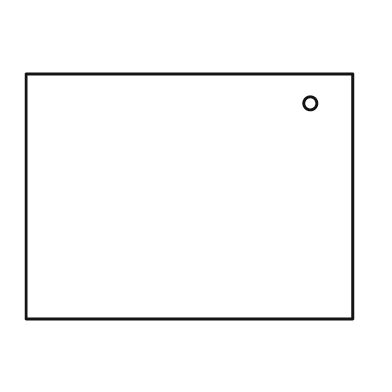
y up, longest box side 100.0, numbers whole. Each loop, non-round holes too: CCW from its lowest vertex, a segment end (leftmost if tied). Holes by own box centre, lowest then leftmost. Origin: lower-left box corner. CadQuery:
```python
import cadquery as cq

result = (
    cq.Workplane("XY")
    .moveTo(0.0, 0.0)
    .lineTo(100.0, 0.0)
    .lineTo(100.0, 75.0)
    .lineTo(0.0, 75.0)
    .close()
    .moveTo(87.0, 66.0)
    .circle(2.0)
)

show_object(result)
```